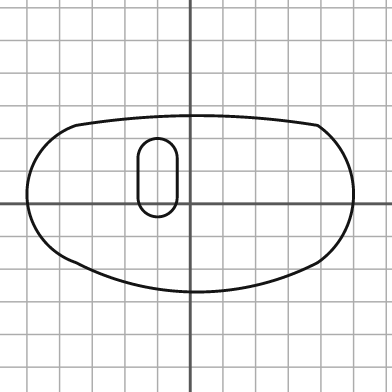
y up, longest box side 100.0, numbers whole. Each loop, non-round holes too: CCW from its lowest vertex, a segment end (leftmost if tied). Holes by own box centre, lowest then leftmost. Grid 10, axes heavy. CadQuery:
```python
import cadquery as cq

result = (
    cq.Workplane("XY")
    .moveTo(-35.0, -18.0)
    .threePointArc((2.0, -27.0), (39.0, -18.0))
    .threePointArc((50.0, 3.0), (39.0, 24.0))
    .threePointArc((2.0, 27.0), (-35.0, 24.0))
    .threePointArc((-50.0, 3.0), (-35.0, -18.0))
    .close()
    .moveTo(-16.0, 2.0)
    .threePointArc((-10.0, -4.0), (-4.0, 2.0))
    .lineTo(-4.0, 14.0)
    .threePointArc((-10.0, 20.0), (-16.0, 14.0))
    .close()
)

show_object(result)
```